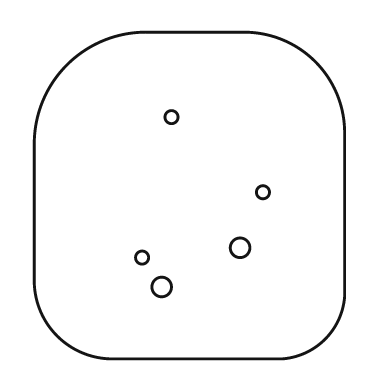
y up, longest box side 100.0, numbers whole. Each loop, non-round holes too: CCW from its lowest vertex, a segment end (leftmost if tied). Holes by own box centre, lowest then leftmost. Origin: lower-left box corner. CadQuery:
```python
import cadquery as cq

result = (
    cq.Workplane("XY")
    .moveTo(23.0, 0.0)
    .lineTo(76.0, 0.0)
    .threePointArc((89.0, 6.0), (95.0, 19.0))
    .lineTo(95.0, 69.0)
    .threePointArc((86.0, 91.0), (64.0, 100.0))
    .lineTo(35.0, 100.0)
    .threePointArc((10.0, 90.0), (0.0, 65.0))
    .lineTo(0.0, 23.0)
    .threePointArc((7.0, 7.0), (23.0, 0.0))
    .close()
    .moveTo(39.0, 22.0)
    .circle(3.0)
    .moveTo(33.0, 31.0)
    .circle(2.0)
    .moveTo(63.0, 34.0)
    .circle(3.0)
    .moveTo(70.0, 51.0)
    .circle(2.0)
    .moveTo(42.0, 74.0)
    .circle(2.0)
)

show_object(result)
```